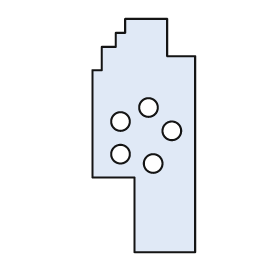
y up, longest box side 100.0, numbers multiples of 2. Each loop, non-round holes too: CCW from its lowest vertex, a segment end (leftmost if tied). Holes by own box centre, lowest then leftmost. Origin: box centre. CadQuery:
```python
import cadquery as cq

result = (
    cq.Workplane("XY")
    .moveTo(-4.0, -50.0)
    .lineTo(22.0, -50.0)
    .lineTo(22.0, 34.0)
    .lineTo(10.0, 34.0)
    .lineTo(10.0, 50.0)
    .lineTo(-8.0, 50.0)
    .lineTo(-8.0, 44.0)
    .lineTo(-12.0, 44.0)
    .lineTo(-12.0, 38.0)
    .lineTo(-18.0, 38.0)
    .lineTo(-18.0, 28.0)
    .lineTo(-22.0, 28.0)
    .lineTo(-22.0, -18.0)
    .lineTo(-4.0, -18.0)
    .close()
    .moveTo(4.0, -12.0)
    .circle(4.0)
    .moveTo(-10.0, -8.0)
    .circle(4.0)
    .moveTo(12.0, 2.0)
    .circle(4.0)
    .moveTo(-10.0, 6.0)
    .circle(4.0)
    .moveTo(2.0, 12.0)
    .circle(4.0)
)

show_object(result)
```